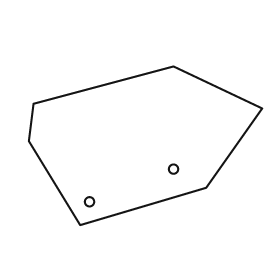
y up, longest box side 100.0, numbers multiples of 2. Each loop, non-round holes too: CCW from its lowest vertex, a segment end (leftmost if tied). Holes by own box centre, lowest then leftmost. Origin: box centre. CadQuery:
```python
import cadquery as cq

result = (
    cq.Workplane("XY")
    .moveTo(-28.0, -34.0)
    .lineTo(26.0, -18.0)
    .lineTo(50.0, 16.0)
    .lineTo(12.0, 34.0)
    .lineTo(-48.0, 18.0)
    .lineTo(-50.0, 2.0)
    .close()
    .moveTo(-24.0, -24.0)
    .circle(2.0)
    .moveTo(12.0, -10.0)
    .circle(2.0)
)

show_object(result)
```